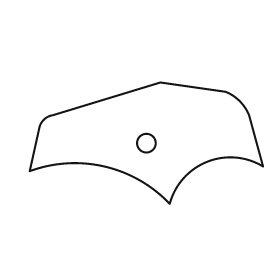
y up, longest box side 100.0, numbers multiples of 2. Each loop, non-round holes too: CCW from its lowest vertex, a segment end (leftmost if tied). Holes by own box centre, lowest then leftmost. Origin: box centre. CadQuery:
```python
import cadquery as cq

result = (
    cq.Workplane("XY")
    .moveTo(10.0, -26.0)
    .threePointArc((26.0, -8.0), (50.0, -10.0))
    .lineTo(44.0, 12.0)
    .threePointArc((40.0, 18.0), (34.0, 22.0))
    .lineTo(6.0, 26.0)
    .lineTo(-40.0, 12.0)
    .threePointArc((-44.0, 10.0), (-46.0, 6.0))
    .lineTo(-50.0, -12.0)
    .threePointArc((-18.0, -10.0), (10.0, -26.0))
    .close()
    .moveTo(0.0, 0.0)
    .circle(4.0)
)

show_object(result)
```